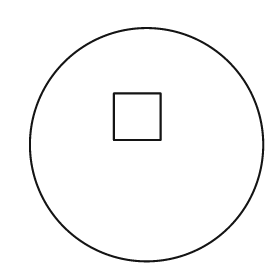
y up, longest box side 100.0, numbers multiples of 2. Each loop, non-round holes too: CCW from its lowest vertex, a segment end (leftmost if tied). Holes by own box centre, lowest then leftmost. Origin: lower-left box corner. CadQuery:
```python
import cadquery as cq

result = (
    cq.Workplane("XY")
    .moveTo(50.0, 50.0)
    .circle(50.0)
    .moveTo(36.0, 52.0)
    .lineTo(56.0, 52.0)
    .lineTo(56.0, 72.0)
    .lineTo(36.0, 72.0)
    .close()
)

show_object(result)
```